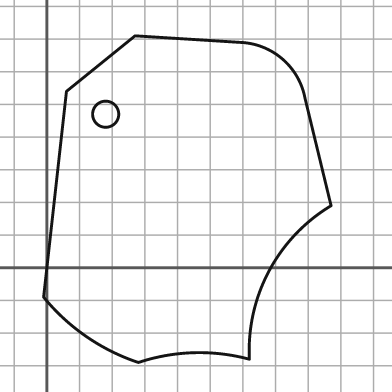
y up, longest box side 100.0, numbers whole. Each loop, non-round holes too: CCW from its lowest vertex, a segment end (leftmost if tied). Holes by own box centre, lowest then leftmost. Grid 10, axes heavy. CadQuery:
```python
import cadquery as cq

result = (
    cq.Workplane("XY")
    .moveTo(28.0, -29.0)
    .threePointArc((45.0, -26.0), (62.0, -28.0))
    .threePointArc((68.0, -1.0), (87.0, 19.0))
    .lineTo(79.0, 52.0)
    .threePointArc((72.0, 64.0), (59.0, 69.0))
    .lineTo(27.0, 71.0)
    .lineTo(6.0, 54.0)
    .lineTo(-1.0, -9.0)
    .threePointArc((12.0, -21.0), (28.0, -29.0))
    .close()
    .moveTo(18.0, 47.0)
    .circle(4.0)
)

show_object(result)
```